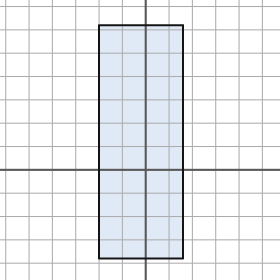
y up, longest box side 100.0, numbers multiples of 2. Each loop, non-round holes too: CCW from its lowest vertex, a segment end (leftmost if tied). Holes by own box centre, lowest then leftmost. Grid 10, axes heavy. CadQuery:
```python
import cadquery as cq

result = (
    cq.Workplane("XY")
    .moveTo(-20.0, -38.0)
    .lineTo(16.0, -38.0)
    .lineTo(16.0, 62.0)
    .lineTo(-20.0, 62.0)
    .close()
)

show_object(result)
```